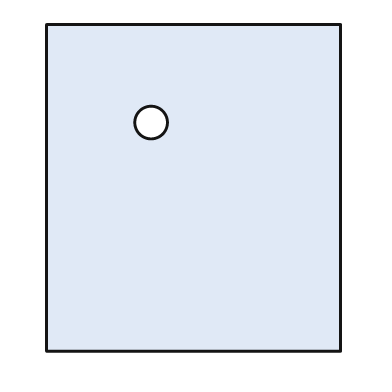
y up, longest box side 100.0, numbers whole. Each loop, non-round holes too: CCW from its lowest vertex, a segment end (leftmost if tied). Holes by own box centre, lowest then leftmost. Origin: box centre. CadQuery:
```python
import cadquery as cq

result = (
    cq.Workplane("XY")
    .moveTo(-45.0, -50.0)
    .lineTo(45.0, -50.0)
    .lineTo(45.0, 50.0)
    .lineTo(-45.0, 50.0)
    .close()
    .moveTo(-13.0, 20.0)
    .circle(5.0)
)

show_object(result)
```